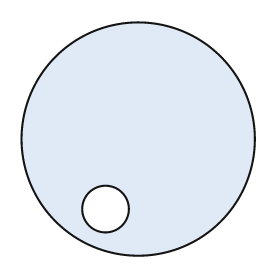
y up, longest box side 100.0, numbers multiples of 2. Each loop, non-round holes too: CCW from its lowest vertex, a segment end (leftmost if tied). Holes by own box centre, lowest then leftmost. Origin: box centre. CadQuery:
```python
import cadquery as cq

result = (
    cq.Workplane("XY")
    .moveTo(0.0, 0.0)
    .circle(50.0)
    .moveTo(-14.0, -30.0)
    .circle(10.0)
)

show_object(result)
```